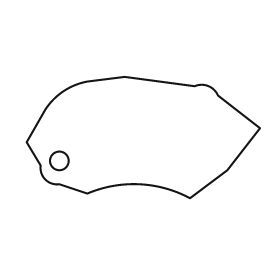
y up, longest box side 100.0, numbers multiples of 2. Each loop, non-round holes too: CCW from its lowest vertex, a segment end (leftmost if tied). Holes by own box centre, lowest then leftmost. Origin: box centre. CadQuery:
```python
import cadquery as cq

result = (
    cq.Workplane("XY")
    .moveTo(20.0, -26.0)
    .lineTo(36.0, -14.0)
    .lineTo(50.0, 4.0)
    .lineTo(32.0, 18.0)
    .threePointArc((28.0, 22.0), (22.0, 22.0))
    .lineTo(-8.0, 26.0)
    .lineTo(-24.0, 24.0)
    .threePointArc((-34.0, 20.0), (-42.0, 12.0))
    .lineTo(-50.0, -2.0)
    .lineTo(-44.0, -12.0)
    .threePointArc((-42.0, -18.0), (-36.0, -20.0))
    .lineTo(-24.0, -24.0)
    .threePointArc((-2.0, -20.0), (20.0, -26.0))
    .close()
    .moveTo(-36.0, -10.0)
    .circle(4.0)
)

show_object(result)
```